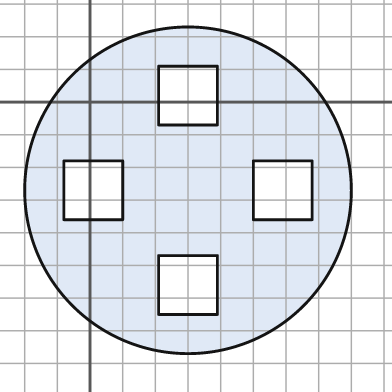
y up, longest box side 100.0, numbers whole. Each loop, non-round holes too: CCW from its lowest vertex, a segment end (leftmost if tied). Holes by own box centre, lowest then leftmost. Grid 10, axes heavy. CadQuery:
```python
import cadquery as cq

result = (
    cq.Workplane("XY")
    .moveTo(30.0, -27.0)
    .circle(50.0)
    .moveTo(21.0, -65.0)
    .lineTo(39.0, -65.0)
    .lineTo(39.0, -47.0)
    .lineTo(21.0, -47.0)
    .close()
    .moveTo(-8.0, -36.0)
    .lineTo(10.0, -36.0)
    .lineTo(10.0, -18.0)
    .lineTo(-8.0, -18.0)
    .close()
    .moveTo(50.0, -36.0)
    .lineTo(68.0, -36.0)
    .lineTo(68.0, -18.0)
    .lineTo(50.0, -18.0)
    .close()
    .moveTo(21.0, -7.0)
    .lineTo(39.0, -7.0)
    .lineTo(39.0, 11.0)
    .lineTo(21.0, 11.0)
    .close()
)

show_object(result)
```